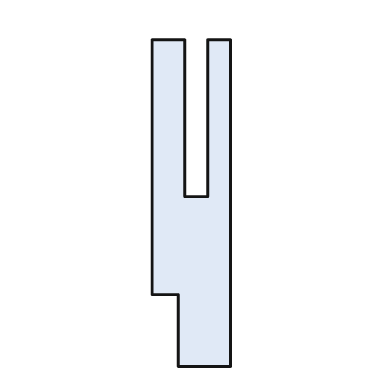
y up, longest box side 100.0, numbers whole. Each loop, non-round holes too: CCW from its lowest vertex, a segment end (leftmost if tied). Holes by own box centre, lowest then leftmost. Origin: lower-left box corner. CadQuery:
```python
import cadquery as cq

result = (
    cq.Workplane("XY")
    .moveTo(8.0, 0.0)
    .lineTo(24.0, 0.0)
    .lineTo(24.0, 100.0)
    .lineTo(17.0, 100.0)
    .lineTo(17.0, 52.0)
    .lineTo(10.0, 52.0)
    .lineTo(10.0, 100.0)
    .lineTo(0.0, 100.0)
    .lineTo(0.0, 22.0)
    .lineTo(8.0, 22.0)
    .close()
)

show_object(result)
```